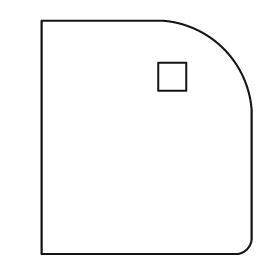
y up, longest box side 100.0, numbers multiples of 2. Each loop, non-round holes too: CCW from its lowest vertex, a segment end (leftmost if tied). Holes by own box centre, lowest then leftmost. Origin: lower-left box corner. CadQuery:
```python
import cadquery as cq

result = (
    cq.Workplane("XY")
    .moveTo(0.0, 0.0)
    .lineTo(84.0, 0.0)
    .threePointArc((88.0, 2.0), (90.0, 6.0))
    .lineTo(90.0, 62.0)
    .threePointArc((78.0, 88.0), (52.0, 100.0))
    .lineTo(0.0, 100.0)
    .close()
    .moveTo(50.0, 70.0)
    .lineTo(62.0, 70.0)
    .lineTo(62.0, 82.0)
    .lineTo(50.0, 82.0)
    .close()
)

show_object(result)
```